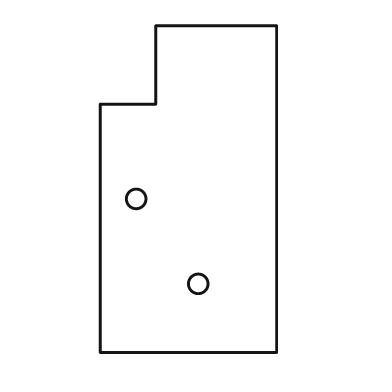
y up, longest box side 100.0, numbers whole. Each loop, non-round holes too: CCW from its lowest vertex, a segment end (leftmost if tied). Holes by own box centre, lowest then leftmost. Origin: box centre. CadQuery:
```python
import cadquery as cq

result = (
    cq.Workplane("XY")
    .moveTo(-27.0, -50.0)
    .lineTo(27.0, -50.0)
    .lineTo(27.0, 50.0)
    .lineTo(-10.0, 50.0)
    .lineTo(-10.0, 26.0)
    .lineTo(-27.0, 26.0)
    .close()
    .moveTo(3.0, -29.0)
    .circle(3.0)
    .moveTo(-16.0, -3.0)
    .circle(3.0)
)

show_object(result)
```